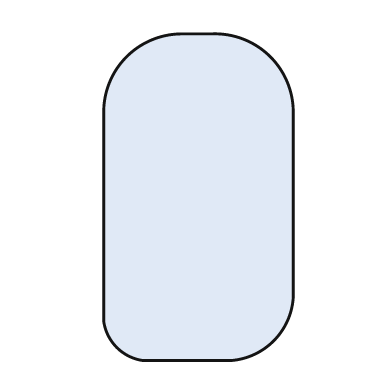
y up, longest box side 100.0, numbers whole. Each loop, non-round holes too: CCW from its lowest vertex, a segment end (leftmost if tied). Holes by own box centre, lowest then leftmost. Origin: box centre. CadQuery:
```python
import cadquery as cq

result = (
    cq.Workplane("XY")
    .moveTo(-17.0, -50.0)
    .lineTo(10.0, -50.0)
    .threePointArc((23.0, -44.0), (29.0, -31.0))
    .lineTo(29.0, 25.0)
    .threePointArc((22.0, 43.0), (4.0, 50.0))
    .lineTo(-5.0, 50.0)
    .threePointArc((-22.0, 43.0), (-29.0, 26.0))
    .lineTo(-29.0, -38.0)
    .threePointArc((-25.0, -46.0), (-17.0, -50.0))
    .close()
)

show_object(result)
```